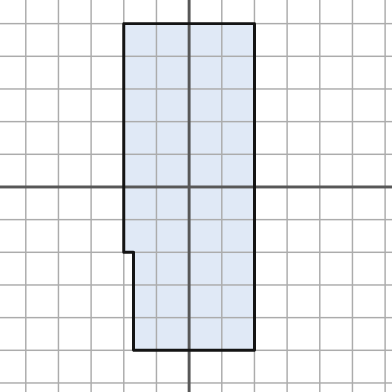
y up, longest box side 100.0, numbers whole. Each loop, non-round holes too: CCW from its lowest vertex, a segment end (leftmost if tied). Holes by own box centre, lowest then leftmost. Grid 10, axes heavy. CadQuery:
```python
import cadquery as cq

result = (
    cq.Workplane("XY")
    .moveTo(-17.0, -50.0)
    .lineTo(20.0, -50.0)
    .lineTo(20.0, 50.0)
    .lineTo(-20.0, 50.0)
    .lineTo(-20.0, -20.0)
    .lineTo(-17.0, -20.0)
    .close()
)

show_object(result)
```